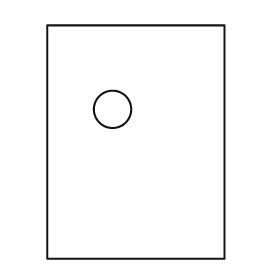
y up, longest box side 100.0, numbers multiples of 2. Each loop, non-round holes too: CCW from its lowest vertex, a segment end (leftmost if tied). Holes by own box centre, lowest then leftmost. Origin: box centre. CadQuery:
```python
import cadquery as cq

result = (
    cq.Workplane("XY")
    .moveTo(-38.0, -50.0)
    .lineTo(38.0, -50.0)
    .lineTo(38.0, 50.0)
    .lineTo(-38.0, 50.0)
    .close()
    .moveTo(-10.0, 14.0)
    .circle(8.0)
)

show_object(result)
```